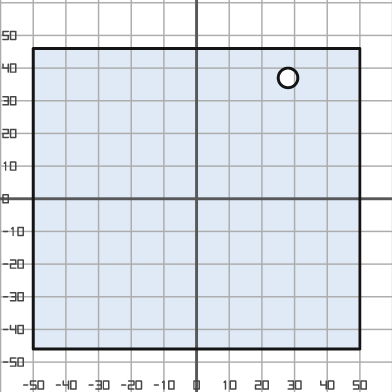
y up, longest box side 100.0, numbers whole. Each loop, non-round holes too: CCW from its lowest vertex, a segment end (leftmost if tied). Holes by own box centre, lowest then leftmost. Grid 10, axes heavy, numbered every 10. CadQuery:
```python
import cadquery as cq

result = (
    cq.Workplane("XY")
    .moveTo(-50.0, -46.0)
    .lineTo(50.0, -46.0)
    .lineTo(50.0, 46.0)
    .lineTo(-50.0, 46.0)
    .close()
    .moveTo(28.0, 37.0)
    .circle(3.0)
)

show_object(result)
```